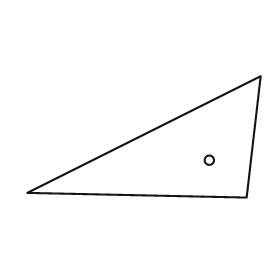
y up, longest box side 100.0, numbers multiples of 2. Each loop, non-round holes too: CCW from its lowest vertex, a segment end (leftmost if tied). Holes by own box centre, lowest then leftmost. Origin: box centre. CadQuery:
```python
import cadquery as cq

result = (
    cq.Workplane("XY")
    .moveTo(44.0, -26.0)
    .lineTo(50.0, 26.0)
    .lineTo(-50.0, -24.0)
    .close()
    .moveTo(28.0, -10.0)
    .circle(2.0)
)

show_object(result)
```